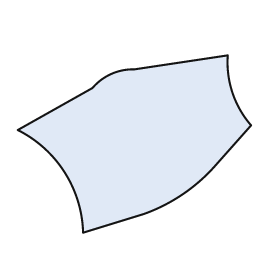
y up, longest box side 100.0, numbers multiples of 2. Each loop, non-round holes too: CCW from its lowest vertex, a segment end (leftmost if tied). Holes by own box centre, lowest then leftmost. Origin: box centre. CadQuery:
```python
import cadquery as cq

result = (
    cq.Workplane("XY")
    .moveTo(-22.0, -38.0)
    .lineTo(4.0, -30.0)
    .threePointArc((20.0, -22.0), (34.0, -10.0))
    .lineTo(50.0, 8.0)
    .threePointArc((42.0, 22.0), (40.0, 38.0))
    .lineTo(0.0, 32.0)
    .threePointArc((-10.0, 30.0), (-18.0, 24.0))
    .lineTo(-50.0, 6.0)
    .threePointArc((-30.0, -12.0), (-22.0, -38.0))
    .close()
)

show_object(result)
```